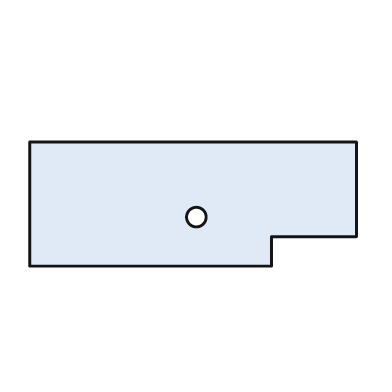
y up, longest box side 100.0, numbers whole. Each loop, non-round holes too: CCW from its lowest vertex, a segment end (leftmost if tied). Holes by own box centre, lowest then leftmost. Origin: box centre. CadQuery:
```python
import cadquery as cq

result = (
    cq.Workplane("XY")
    .moveTo(-50.0, -19.0)
    .lineTo(24.0, -19.0)
    .lineTo(24.0, -10.0)
    .lineTo(50.0, -10.0)
    .lineTo(50.0, 19.0)
    .lineTo(-50.0, 19.0)
    .close()
    .moveTo(1.0, -4.0)
    .circle(3.0)
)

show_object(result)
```